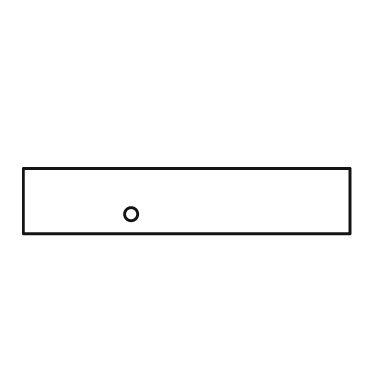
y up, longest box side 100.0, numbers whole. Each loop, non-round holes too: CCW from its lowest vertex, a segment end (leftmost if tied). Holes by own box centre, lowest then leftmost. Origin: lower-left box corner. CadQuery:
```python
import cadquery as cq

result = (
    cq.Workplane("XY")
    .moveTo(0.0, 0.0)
    .lineTo(100.0, 0.0)
    .lineTo(100.0, 20.0)
    .lineTo(0.0, 20.0)
    .close()
    .moveTo(33.0, 6.0)
    .circle(2.0)
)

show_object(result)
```